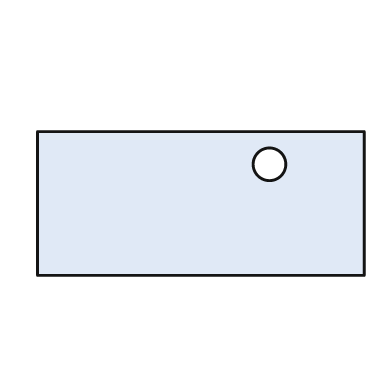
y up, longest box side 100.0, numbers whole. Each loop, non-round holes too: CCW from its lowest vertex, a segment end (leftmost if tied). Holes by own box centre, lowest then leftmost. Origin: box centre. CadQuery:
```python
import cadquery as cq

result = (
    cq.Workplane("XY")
    .moveTo(-50.0, -22.0)
    .lineTo(50.0, -22.0)
    .lineTo(50.0, 22.0)
    .lineTo(-50.0, 22.0)
    .close()
    .moveTo(21.0, 12.0)
    .circle(5.0)
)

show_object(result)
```